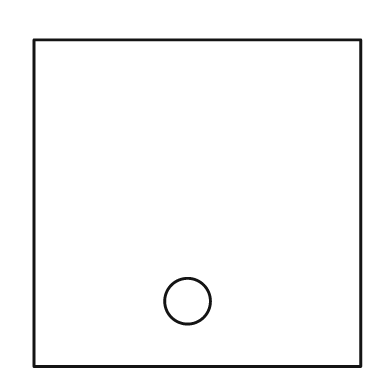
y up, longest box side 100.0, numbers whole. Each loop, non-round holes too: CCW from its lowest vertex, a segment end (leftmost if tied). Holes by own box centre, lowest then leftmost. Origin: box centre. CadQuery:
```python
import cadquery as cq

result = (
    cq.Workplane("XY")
    .moveTo(-50.0, -50.0)
    .lineTo(50.0, -50.0)
    .lineTo(50.0, 50.0)
    .lineTo(-50.0, 50.0)
    .close()
    .moveTo(-3.0, -30.0)
    .circle(7.0)
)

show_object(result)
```